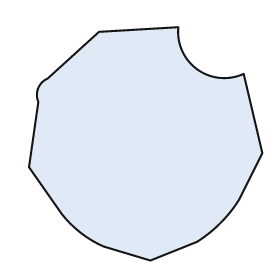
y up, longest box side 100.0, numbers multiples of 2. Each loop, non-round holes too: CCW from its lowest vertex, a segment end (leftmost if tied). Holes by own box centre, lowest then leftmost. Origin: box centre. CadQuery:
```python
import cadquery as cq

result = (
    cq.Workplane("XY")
    .moveTo(2.0, -50.0)
    .lineTo(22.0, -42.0)
    .threePointArc((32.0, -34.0), (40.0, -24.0))
    .lineTo(50.0, -4.0)
    .lineTo(42.0, 30.0)
    .threePointArc((22.0, 32.0), (14.0, 50.0))
    .lineTo(-20.0, 48.0)
    .lineTo(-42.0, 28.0)
    .threePointArc((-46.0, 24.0), (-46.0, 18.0))
    .lineTo(-50.0, -10.0)
    .lineTo(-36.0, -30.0)
    .threePointArc((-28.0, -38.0), (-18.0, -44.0))
    .close()
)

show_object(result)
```